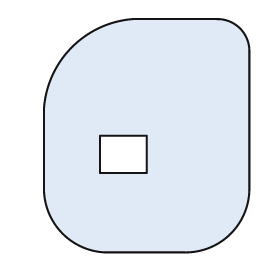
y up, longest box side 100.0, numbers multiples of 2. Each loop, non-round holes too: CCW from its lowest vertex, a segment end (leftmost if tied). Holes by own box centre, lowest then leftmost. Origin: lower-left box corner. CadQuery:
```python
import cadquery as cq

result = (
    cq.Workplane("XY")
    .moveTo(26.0, 0.0)
    .lineTo(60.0, 0.0)
    .threePointArc((80.0, 8.0), (88.0, 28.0))
    .lineTo(88.0, 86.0)
    .threePointArc((84.0, 96.0), (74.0, 100.0))
    .lineTo(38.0, 100.0)
    .threePointArc((12.0, 88.0), (0.0, 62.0))
    .lineTo(0.0, 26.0)
    .threePointArc((8.0, 8.0), (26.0, 0.0))
    .close()
    .moveTo(24.0, 34.0)
    .lineTo(44.0, 34.0)
    .lineTo(44.0, 50.0)
    .lineTo(24.0, 50.0)
    .close()
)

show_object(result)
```